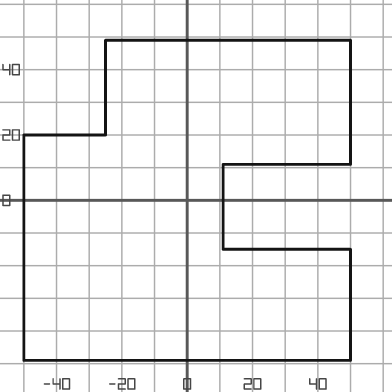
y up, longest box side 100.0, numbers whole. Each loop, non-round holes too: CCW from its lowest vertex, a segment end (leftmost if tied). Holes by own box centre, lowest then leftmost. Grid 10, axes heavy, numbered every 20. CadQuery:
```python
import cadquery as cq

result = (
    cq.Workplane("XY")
    .moveTo(-50.0, -49.0)
    .lineTo(50.0, -49.0)
    .lineTo(50.0, -15.0)
    .lineTo(11.0, -15.0)
    .lineTo(11.0, 11.0)
    .lineTo(50.0, 11.0)
    .lineTo(50.0, 49.0)
    .lineTo(-25.0, 49.0)
    .lineTo(-25.0, 20.0)
    .lineTo(-50.0, 20.0)
    .close()
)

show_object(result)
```